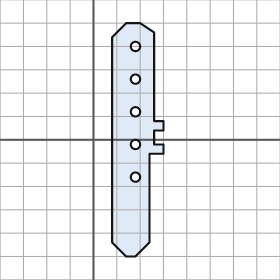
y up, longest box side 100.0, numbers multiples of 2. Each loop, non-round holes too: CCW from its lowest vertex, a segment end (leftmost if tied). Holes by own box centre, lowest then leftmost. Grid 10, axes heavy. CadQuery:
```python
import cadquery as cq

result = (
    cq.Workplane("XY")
    .moveTo(14.0, -50.0)
    .lineTo(18.0, -50.0)
    .lineTo(24.0, -44.0)
    .lineTo(24.0, -6.0)
    .lineTo(30.0, -6.0)
    .lineTo(30.0, -2.0)
    .lineTo(26.0, -2.0)
    .lineTo(26.0, 4.0)
    .lineTo(30.0, 4.0)
    .lineTo(30.0, 8.0)
    .lineTo(26.0, 8.0)
    .lineTo(26.0, 46.0)
    .lineTo(20.0, 50.0)
    .lineTo(14.0, 50.0)
    .lineTo(8.0, 44.0)
    .lineTo(8.0, -44.0)
    .close()
    .moveTo(18.0, -16.0)
    .circle(2.0)
    .moveTo(18.0, -2.0)
    .circle(2.0)
    .moveTo(18.0, 12.0)
    .circle(2.0)
    .moveTo(18.0, 26.0)
    .circle(2.0)
    .moveTo(18.0, 40.0)
    .circle(2.0)
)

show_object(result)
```